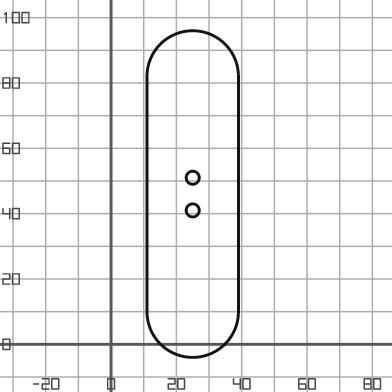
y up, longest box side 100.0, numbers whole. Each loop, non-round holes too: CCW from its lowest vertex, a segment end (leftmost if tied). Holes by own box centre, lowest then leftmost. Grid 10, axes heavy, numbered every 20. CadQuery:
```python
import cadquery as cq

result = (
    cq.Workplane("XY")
    .moveTo(11.0, 10.0)
    .threePointArc((25.0, -4.0), (39.0, 10.0))
    .lineTo(39.0, 82.0)
    .threePointArc((25.0, 96.0), (11.0, 82.0))
    .close()
    .moveTo(25.0, 41.0)
    .circle(2.0)
    .moveTo(25.0, 51.0)
    .circle(2.0)
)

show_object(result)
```